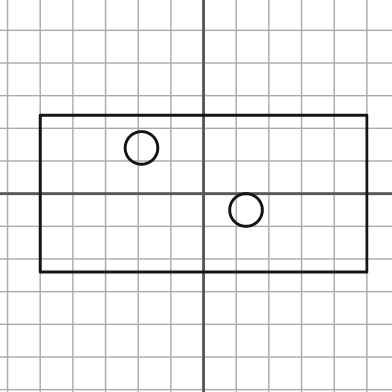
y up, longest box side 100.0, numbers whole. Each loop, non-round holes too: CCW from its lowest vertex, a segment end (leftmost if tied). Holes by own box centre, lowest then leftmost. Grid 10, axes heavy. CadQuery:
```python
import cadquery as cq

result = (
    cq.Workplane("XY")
    .moveTo(-50.0, -24.0)
    .lineTo(50.0, -24.0)
    .lineTo(50.0, 24.0)
    .lineTo(-50.0, 24.0)
    .close()
    .moveTo(13.0, -5.0)
    .circle(5.0)
    .moveTo(-19.0, 14.0)
    .circle(5.0)
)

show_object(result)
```